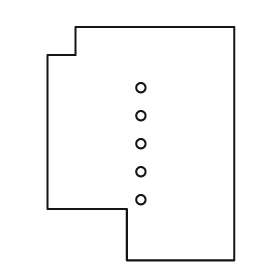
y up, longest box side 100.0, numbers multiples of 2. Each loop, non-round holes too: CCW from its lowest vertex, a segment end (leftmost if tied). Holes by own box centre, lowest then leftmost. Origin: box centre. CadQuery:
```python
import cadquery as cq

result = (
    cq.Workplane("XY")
    .moveTo(-6.0, -50.0)
    .lineTo(40.0, -50.0)
    .lineTo(40.0, 50.0)
    .lineTo(-28.0, 50.0)
    .lineTo(-28.0, 38.0)
    .lineTo(-40.0, 38.0)
    .lineTo(-40.0, -28.0)
    .lineTo(-6.0, -28.0)
    .close()
    .moveTo(0.0, -24.0)
    .circle(2.0)
    .moveTo(0.0, -12.0)
    .circle(2.0)
    .moveTo(0.0, 0.0)
    .circle(2.0)
    .moveTo(0.0, 12.0)
    .circle(2.0)
    .moveTo(0.0, 24.0)
    .circle(2.0)
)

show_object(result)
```